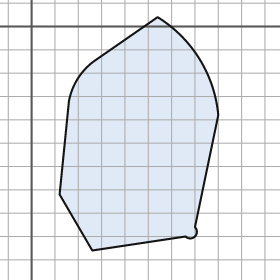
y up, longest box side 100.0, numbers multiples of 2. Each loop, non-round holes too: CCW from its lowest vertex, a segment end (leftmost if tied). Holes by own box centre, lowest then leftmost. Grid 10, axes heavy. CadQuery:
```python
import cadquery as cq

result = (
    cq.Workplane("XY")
    .moveTo(26.0, -96.0)
    .lineTo(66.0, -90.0)
    .threePointArc((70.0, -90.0), (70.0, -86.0))
    .lineTo(80.0, -38.0)
    .threePointArc((72.0, -14.0), (54.0, 4.0))
    .lineTo(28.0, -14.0)
    .threePointArc((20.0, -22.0), (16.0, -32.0))
    .lineTo(12.0, -72.0)
    .close()
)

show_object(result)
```